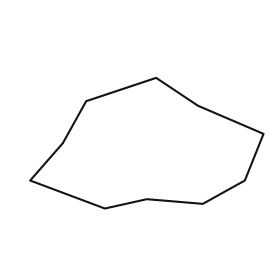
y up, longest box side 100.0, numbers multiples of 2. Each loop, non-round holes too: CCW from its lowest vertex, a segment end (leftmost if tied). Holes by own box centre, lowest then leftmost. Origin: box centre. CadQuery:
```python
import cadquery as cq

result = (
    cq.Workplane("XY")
    .moveTo(-18.0, -28.0)
    .lineTo(0.0, -24.0)
    .lineTo(24.0, -26.0)
    .lineTo(42.0, -16.0)
    .lineTo(50.0, 4.0)
    .lineTo(22.0, 16.0)
    .lineTo(4.0, 28.0)
    .lineTo(-26.0, 18.0)
    .lineTo(-36.0, 0.0)
    .lineTo(-50.0, -16.0)
    .close()
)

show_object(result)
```